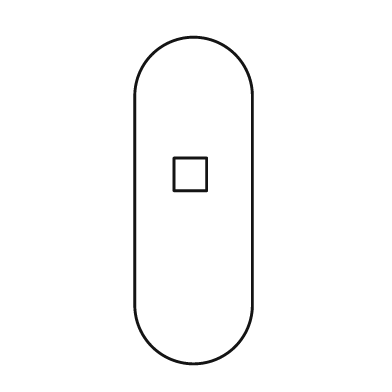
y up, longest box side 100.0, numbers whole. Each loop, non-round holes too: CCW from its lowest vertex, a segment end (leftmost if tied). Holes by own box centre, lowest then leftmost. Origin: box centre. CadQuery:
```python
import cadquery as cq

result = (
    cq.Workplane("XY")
    .moveTo(-18.0, -32.0)
    .threePointArc((0.0, -50.0), (18.0, -32.0))
    .lineTo(18.0, 32.0)
    .threePointArc((0.0, 50.0), (-18.0, 32.0))
    .close()
    .moveTo(-6.0, 3.0)
    .lineTo(4.0, 3.0)
    .lineTo(4.0, 13.0)
    .lineTo(-6.0, 13.0)
    .close()
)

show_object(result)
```